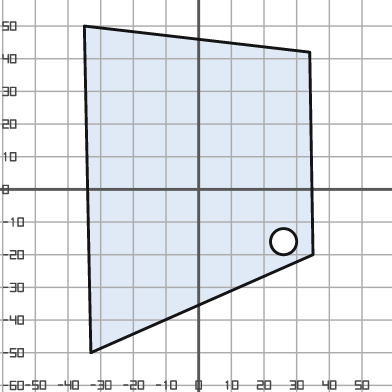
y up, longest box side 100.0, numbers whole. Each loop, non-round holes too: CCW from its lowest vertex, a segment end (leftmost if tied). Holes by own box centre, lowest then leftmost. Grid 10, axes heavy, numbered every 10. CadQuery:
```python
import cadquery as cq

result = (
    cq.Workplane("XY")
    .moveTo(-33.0, -50.0)
    .lineTo(35.0, -20.0)
    .lineTo(34.0, 42.0)
    .lineTo(-35.0, 50.0)
    .close()
    .moveTo(26.0, -16.0)
    .circle(4.0)
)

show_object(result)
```